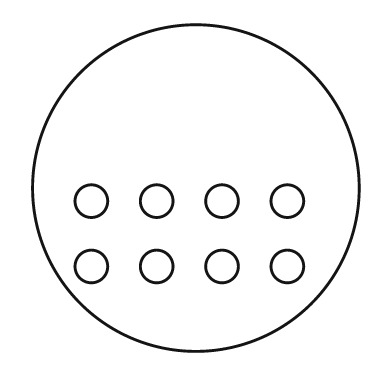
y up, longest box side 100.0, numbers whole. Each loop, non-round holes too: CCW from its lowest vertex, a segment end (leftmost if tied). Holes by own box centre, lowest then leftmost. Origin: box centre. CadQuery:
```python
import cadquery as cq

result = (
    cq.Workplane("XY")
    .moveTo(0.0, 0.0)
    .circle(50.0)
    .moveTo(-32.0, -24.0)
    .circle(5.0)
    .moveTo(-12.0, -24.0)
    .circle(5.0)
    .moveTo(8.0, -24.0)
    .circle(5.0)
    .moveTo(28.0, -24.0)
    .circle(5.0)
    .moveTo(-32.0, -4.0)
    .circle(5.0)
    .moveTo(-12.0, -4.0)
    .circle(5.0)
    .moveTo(8.0, -4.0)
    .circle(5.0)
    .moveTo(28.0, -4.0)
    .circle(5.0)
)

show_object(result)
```